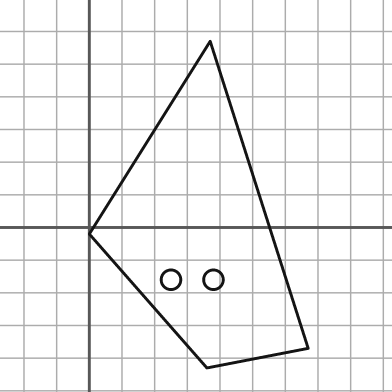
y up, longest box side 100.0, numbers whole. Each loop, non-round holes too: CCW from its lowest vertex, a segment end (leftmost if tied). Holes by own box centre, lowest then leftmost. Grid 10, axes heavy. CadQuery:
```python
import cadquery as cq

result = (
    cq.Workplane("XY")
    .moveTo(36.0, -43.0)
    .lineTo(67.0, -37.0)
    .lineTo(37.0, 57.0)
    .lineTo(0.0, -2.0)
    .close()
    .moveTo(25.0, -16.0)
    .circle(3.0)
    .moveTo(38.0, -16.0)
    .circle(3.0)
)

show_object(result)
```